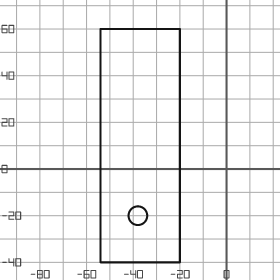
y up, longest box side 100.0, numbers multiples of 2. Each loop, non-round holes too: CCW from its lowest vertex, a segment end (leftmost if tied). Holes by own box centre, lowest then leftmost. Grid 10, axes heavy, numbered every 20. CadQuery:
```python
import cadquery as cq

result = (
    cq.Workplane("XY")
    .moveTo(-54.0, -40.0)
    .lineTo(-20.0, -40.0)
    .lineTo(-20.0, 60.0)
    .lineTo(-54.0, 60.0)
    .close()
    .moveTo(-38.0, -20.0)
    .circle(4.0)
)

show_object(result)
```